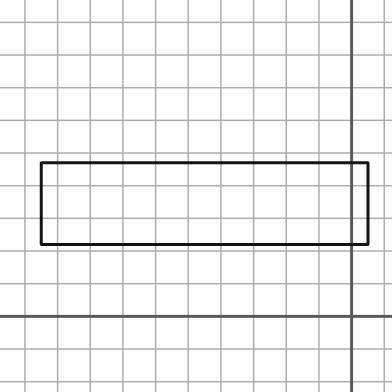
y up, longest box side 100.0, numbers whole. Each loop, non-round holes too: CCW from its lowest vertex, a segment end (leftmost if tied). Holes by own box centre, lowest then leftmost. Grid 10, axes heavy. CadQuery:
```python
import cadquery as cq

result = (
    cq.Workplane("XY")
    .moveTo(-95.0, 22.0)
    .lineTo(5.0, 22.0)
    .lineTo(5.0, 47.0)
    .lineTo(-95.0, 47.0)
    .close()
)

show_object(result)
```